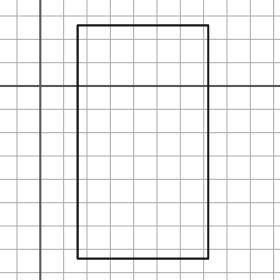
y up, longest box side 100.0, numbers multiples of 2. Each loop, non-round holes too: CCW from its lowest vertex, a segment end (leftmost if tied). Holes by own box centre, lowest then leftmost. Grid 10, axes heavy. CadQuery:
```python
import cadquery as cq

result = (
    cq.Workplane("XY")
    .moveTo(16.0, -74.0)
    .lineTo(72.0, -74.0)
    .lineTo(72.0, 26.0)
    .lineTo(16.0, 26.0)
    .close()
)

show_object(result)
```